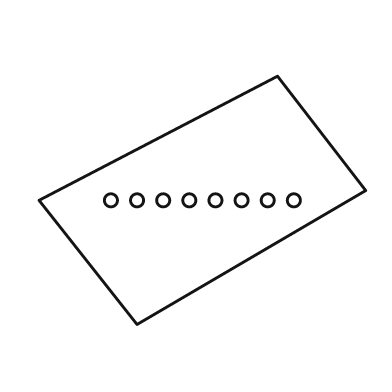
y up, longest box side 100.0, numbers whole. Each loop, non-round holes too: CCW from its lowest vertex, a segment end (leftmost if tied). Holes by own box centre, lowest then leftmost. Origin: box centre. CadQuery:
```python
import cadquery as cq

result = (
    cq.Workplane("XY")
    .moveTo(-20.0, -38.0)
    .lineTo(50.0, 3.0)
    .lineTo(23.0, 38.0)
    .lineTo(-50.0, 0.0)
    .close()
    .moveTo(-28.0, 0.0)
    .circle(2.0)
    .moveTo(-20.0, 0.0)
    .circle(2.0)
    .moveTo(-12.0, 0.0)
    .circle(2.0)
    .moveTo(-4.0, 0.0)
    .circle(2.0)
    .moveTo(4.0, 0.0)
    .circle(2.0)
    .moveTo(12.0, 0.0)
    .circle(2.0)
    .moveTo(20.0, 0.0)
    .circle(2.0)
    .moveTo(28.0, 0.0)
    .circle(2.0)
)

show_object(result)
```